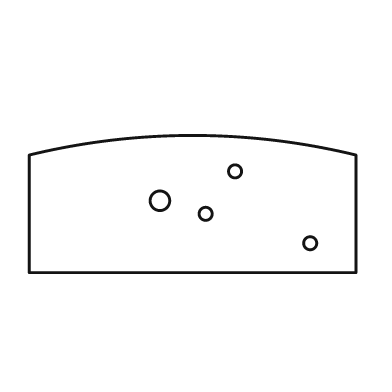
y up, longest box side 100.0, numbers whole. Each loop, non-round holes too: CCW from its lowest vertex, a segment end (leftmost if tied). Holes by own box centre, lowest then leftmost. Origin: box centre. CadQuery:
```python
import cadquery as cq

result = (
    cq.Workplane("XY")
    .moveTo(-50.0, -21.0)
    .lineTo(50.0, -21.0)
    .lineTo(50.0, 15.0)
    .threePointArc((0.0, 21.0), (-50.0, 15.0))
    .close()
    .moveTo(36.0, -12.0)
    .circle(2.0)
    .moveTo(4.0, -3.0)
    .circle(2.0)
    .moveTo(-10.0, 1.0)
    .circle(3.0)
    .moveTo(13.0, 10.0)
    .circle(2.0)
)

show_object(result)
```